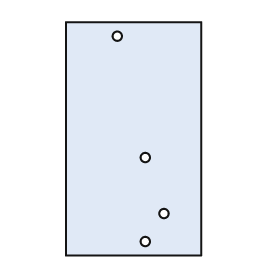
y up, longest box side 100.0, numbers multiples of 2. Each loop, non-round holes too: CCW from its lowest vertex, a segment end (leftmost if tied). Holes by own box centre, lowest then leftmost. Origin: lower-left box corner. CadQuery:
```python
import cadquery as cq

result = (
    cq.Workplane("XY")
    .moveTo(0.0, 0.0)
    .lineTo(58.0, 0.0)
    .lineTo(58.0, 100.0)
    .lineTo(0.0, 100.0)
    .close()
    .moveTo(34.0, 6.0)
    .circle(2.0)
    .moveTo(42.0, 18.0)
    .circle(2.0)
    .moveTo(34.0, 42.0)
    .circle(2.0)
    .moveTo(22.0, 94.0)
    .circle(2.0)
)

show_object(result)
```